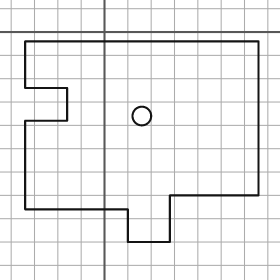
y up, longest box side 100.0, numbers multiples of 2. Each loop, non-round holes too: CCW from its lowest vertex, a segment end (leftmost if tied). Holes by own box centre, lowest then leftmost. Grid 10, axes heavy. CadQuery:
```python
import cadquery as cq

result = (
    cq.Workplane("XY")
    .moveTo(10.0, -90.0)
    .lineTo(28.0, -90.0)
    .lineTo(28.0, -70.0)
    .lineTo(66.0, -70.0)
    .lineTo(66.0, -4.0)
    .lineTo(-34.0, -4.0)
    .lineTo(-34.0, -24.0)
    .lineTo(-16.0, -24.0)
    .lineTo(-16.0, -38.0)
    .lineTo(-34.0, -38.0)
    .lineTo(-34.0, -76.0)
    .lineTo(10.0, -76.0)
    .close()
    .moveTo(16.0, -36.0)
    .circle(4.0)
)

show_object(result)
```